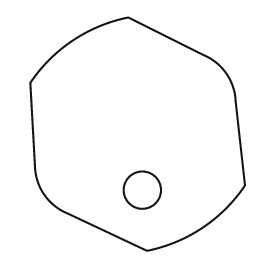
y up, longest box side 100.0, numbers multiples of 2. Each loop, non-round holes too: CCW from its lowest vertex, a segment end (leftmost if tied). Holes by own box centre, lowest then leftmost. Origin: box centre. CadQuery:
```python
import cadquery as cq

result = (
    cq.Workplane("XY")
    .moveTo(4.0, -50.0)
    .threePointArc((28.0, -40.0), (46.0, -22.0))
    .lineTo(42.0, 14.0)
    .threePointArc((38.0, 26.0), (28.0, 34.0))
    .lineTo(-4.0, 50.0)
    .threePointArc((-28.0, 40.0), (-46.0, 22.0))
    .lineTo(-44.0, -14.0)
    .threePointArc((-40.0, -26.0), (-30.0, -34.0))
    .close()
    .moveTo(2.0, -24.0)
    .circle(8.0)
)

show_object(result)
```